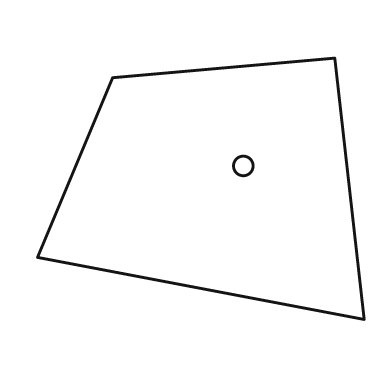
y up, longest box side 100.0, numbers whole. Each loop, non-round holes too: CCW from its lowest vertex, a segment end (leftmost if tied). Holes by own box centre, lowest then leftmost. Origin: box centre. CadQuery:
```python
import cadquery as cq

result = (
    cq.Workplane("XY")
    .moveTo(50.0, -40.0)
    .lineTo(41.0, 40.0)
    .lineTo(-27.0, 34.0)
    .lineTo(-50.0, -21.0)
    .close()
    .moveTo(13.0, 7.0)
    .circle(3.0)
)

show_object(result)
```